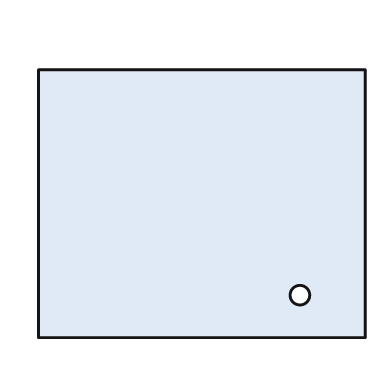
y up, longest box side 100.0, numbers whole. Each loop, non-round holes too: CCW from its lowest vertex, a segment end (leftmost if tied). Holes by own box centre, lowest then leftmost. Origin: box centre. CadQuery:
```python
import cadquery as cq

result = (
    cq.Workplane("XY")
    .moveTo(-50.0, -41.0)
    .lineTo(50.0, -41.0)
    .lineTo(50.0, 41.0)
    .lineTo(-50.0, 41.0)
    .close()
    .moveTo(30.0, -28.0)
    .circle(3.0)
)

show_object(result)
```